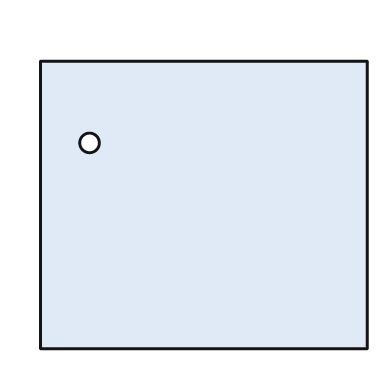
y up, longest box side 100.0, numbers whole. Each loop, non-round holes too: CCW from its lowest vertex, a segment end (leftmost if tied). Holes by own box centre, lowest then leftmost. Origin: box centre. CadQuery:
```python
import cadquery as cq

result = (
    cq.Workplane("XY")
    .moveTo(-50.0, -44.0)
    .lineTo(50.0, -44.0)
    .lineTo(50.0, 44.0)
    .lineTo(-50.0, 44.0)
    .close()
    .moveTo(-35.0, 19.0)
    .circle(3.0)
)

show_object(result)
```